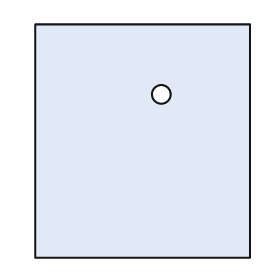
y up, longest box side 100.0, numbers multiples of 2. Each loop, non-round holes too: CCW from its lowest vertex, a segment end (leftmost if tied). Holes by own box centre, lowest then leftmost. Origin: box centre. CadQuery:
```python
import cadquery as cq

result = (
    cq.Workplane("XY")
    .moveTo(-46.0, -50.0)
    .lineTo(46.0, -50.0)
    .lineTo(46.0, 50.0)
    .lineTo(-46.0, 50.0)
    .close()
    .moveTo(8.0, 20.0)
    .circle(4.0)
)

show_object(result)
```